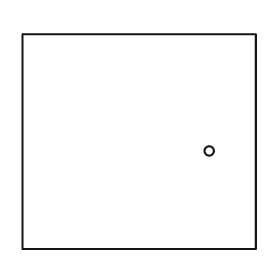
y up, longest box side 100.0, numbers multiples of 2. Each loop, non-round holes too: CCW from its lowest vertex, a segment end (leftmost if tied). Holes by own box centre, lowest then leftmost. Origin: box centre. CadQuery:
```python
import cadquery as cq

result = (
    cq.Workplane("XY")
    .moveTo(-50.0, -46.0)
    .lineTo(50.0, -46.0)
    .lineTo(50.0, 46.0)
    .lineTo(-50.0, 46.0)
    .close()
    .moveTo(30.0, -4.0)
    .circle(2.0)
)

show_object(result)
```